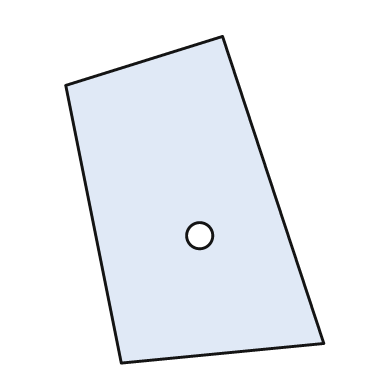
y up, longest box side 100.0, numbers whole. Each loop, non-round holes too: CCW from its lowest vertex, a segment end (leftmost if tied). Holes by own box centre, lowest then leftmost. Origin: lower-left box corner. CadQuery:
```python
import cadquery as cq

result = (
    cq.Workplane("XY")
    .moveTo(17.0, 0.0)
    .lineTo(79.0, 6.0)
    .lineTo(48.0, 100.0)
    .lineTo(0.0, 85.0)
    .close()
    .moveTo(41.0, 39.0)
    .circle(4.0)
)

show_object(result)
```